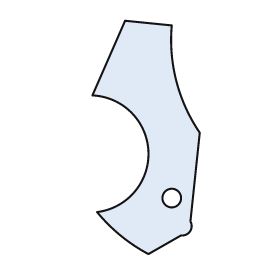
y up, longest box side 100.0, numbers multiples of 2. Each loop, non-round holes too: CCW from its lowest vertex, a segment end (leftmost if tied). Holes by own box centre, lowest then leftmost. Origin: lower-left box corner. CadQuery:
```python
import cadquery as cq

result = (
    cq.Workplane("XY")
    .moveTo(24.0, 0.0)
    .lineTo(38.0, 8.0)
    .threePointArc((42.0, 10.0), (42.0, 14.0))
    .lineTo(46.0, 52.0)
    .threePointArc((36.0, 74.0), (34.0, 98.0))
    .lineTo(14.0, 100.0)
    .lineTo(0.0, 68.0)
    .threePointArc((24.0, 44.0), (2.0, 18.0))
    .threePointArc((12.0, 8.0), (24.0, 0.0))
    .close()
    .moveTo(34.0, 24.0)
    .circle(4.0)
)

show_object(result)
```